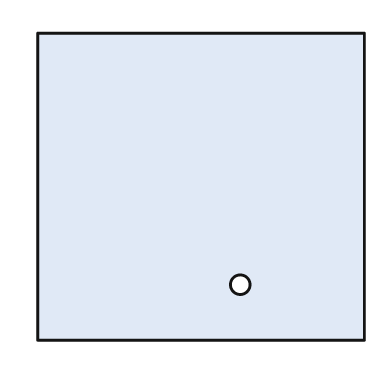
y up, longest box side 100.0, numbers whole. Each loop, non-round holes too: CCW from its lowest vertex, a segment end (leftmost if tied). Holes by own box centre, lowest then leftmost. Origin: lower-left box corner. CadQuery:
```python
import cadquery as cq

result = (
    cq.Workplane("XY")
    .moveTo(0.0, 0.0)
    .lineTo(100.0, 0.0)
    .lineTo(100.0, 94.0)
    .lineTo(0.0, 94.0)
    .close()
    .moveTo(62.0, 17.0)
    .circle(3.0)
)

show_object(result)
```